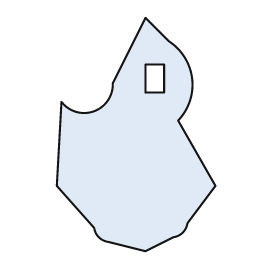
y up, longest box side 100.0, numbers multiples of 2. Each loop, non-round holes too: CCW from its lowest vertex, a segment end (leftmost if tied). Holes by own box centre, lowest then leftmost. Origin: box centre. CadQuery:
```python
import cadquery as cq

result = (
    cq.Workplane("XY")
    .moveTo(4.0, -50.0)
    .lineTo(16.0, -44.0)
    .threePointArc((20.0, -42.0), (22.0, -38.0))
    .lineTo(34.0, -22.0)
    .lineTo(18.0, 6.0)
    .threePointArc((24.0, 24.0), (14.0, 40.0))
    .lineTo(4.0, 50.0)
    .lineTo(-10.0, 22.0)
    .threePointArc((-18.0, 10.0), (-32.0, 14.0))
    .lineTo(-34.0, -22.0)
    .lineTo(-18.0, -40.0)
    .threePointArc((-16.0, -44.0), (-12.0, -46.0))
    .close()
    .moveTo(4.0, 18.0)
    .lineTo(12.0, 18.0)
    .lineTo(12.0, 30.0)
    .lineTo(4.0, 30.0)
    .close()
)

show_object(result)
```